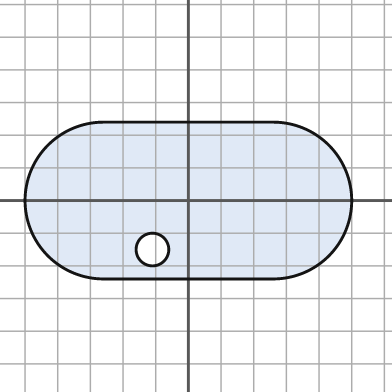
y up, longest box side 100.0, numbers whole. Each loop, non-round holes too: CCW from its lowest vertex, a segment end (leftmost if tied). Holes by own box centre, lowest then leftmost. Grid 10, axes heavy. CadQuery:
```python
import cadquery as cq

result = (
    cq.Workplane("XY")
    .moveTo(-26.0, -24.0)
    .lineTo(26.0, -24.0)
    .threePointArc((50.0, 0.0), (26.0, 24.0))
    .lineTo(-26.0, 24.0)
    .threePointArc((-50.0, 0.0), (-26.0, -24.0))
    .close()
    .moveTo(-11.0, -15.0)
    .circle(5.0)
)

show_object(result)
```